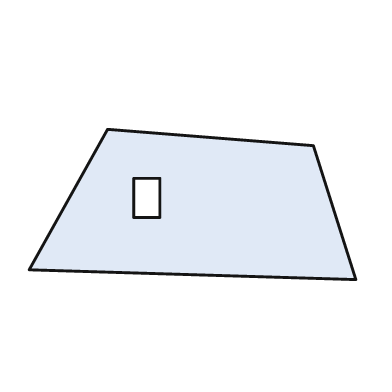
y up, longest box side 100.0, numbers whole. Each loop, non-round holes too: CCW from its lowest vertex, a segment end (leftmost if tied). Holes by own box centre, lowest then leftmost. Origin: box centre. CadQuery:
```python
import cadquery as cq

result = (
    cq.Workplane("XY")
    .moveTo(50.0, -23.0)
    .lineTo(37.0, 18.0)
    .lineTo(-26.0, 23.0)
    .lineTo(-50.0, -20.0)
    .close()
    .moveTo(-18.0, -4.0)
    .lineTo(-10.0, -4.0)
    .lineTo(-10.0, 8.0)
    .lineTo(-18.0, 8.0)
    .close()
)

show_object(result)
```